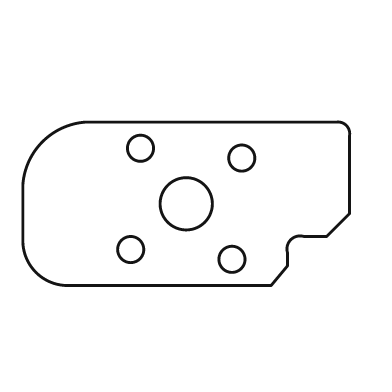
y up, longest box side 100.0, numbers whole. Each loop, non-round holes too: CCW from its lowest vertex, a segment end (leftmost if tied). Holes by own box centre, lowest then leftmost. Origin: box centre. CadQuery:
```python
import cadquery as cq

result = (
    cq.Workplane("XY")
    .moveTo(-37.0, -25.0)
    .lineTo(26.0, -25.0)
    .lineTo(31.0, -19.0)
    .lineTo(31.0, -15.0)
    .threePointArc((32.0, -11.0), (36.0, -10.0))
    .lineTo(43.0, -10.0)
    .lineTo(50.0, -3.0)
    .lineTo(50.0, 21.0)
    .threePointArc((49.0, 24.0), (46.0, 25.0))
    .lineTo(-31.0, 25.0)
    .threePointArc((-44.0, 19.0), (-50.0, 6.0))
    .lineTo(-50.0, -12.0)
    .threePointArc((-46.0, -21.0), (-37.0, -25.0))
    .close()
    .moveTo(14.0, -17.0)
    .circle(4.0)
    .moveTo(-17.0, -14.0)
    .circle(4.0)
    .moveTo(0.0, 0.0)
    .circle(8.0)
    .moveTo(17.0, 14.0)
    .circle(4.0)
    .moveTo(-14.0, 17.0)
    .circle(4.0)
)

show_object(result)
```